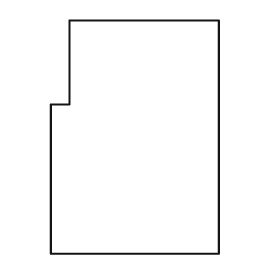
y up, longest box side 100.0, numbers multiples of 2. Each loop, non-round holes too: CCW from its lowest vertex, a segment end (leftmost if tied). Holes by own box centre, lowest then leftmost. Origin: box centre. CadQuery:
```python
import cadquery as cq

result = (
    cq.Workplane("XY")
    .moveTo(-36.0, -50.0)
    .lineTo(36.0, -50.0)
    .lineTo(36.0, 50.0)
    .lineTo(-28.0, 50.0)
    .lineTo(-28.0, 14.0)
    .lineTo(-36.0, 14.0)
    .close()
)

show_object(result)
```